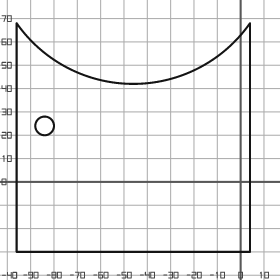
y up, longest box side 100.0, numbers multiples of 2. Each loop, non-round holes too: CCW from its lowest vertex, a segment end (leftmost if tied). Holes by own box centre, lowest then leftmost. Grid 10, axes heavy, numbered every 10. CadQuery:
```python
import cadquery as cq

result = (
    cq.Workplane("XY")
    .moveTo(-96.0, -30.0)
    .lineTo(4.0, -30.0)
    .lineTo(4.0, 68.0)
    .threePointArc((-46.0, 42.0), (-96.0, 68.0))
    .close()
    .moveTo(-84.0, 24.0)
    .circle(4.0)
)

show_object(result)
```